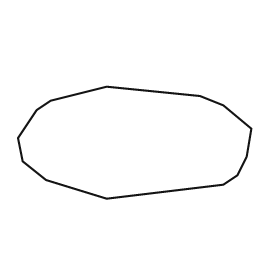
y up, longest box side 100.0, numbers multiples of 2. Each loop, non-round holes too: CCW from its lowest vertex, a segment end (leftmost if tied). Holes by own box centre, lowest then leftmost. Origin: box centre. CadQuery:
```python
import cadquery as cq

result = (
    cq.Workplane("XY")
    .moveTo(-12.0, -24.0)
    .lineTo(38.0, -18.0)
    .lineTo(44.0, -14.0)
    .lineTo(48.0, -6.0)
    .lineTo(50.0, 6.0)
    .lineTo(38.0, 16.0)
    .lineTo(28.0, 20.0)
    .lineTo(-12.0, 24.0)
    .lineTo(-36.0, 18.0)
    .lineTo(-42.0, 14.0)
    .lineTo(-50.0, 2.0)
    .lineTo(-48.0, -8.0)
    .lineTo(-38.0, -16.0)
    .close()
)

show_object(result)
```